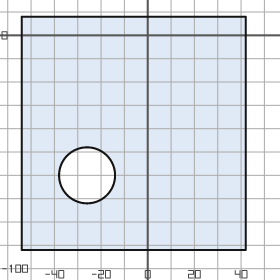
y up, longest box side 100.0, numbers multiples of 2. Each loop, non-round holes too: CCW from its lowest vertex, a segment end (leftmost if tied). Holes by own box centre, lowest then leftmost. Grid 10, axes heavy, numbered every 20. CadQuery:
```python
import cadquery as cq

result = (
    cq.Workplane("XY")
    .moveTo(-54.0, -92.0)
    .lineTo(42.0, -92.0)
    .lineTo(42.0, 8.0)
    .lineTo(-54.0, 8.0)
    .close()
    .moveTo(-26.0, -60.0)
    .circle(12.0)
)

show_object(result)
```